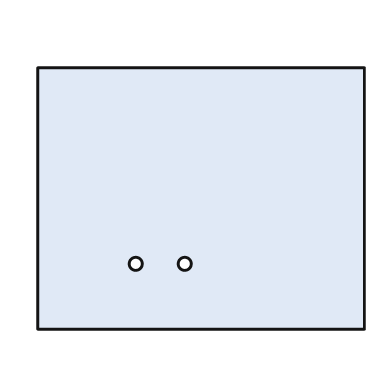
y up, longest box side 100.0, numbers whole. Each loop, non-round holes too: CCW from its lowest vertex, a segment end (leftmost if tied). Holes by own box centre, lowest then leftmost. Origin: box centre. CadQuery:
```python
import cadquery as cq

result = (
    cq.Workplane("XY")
    .moveTo(-50.0, -40.0)
    .lineTo(50.0, -40.0)
    .lineTo(50.0, 40.0)
    .lineTo(-50.0, 40.0)
    .close()
    .moveTo(-20.0, -20.0)
    .circle(2.0)
    .moveTo(-5.0, -20.0)
    .circle(2.0)
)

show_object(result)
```